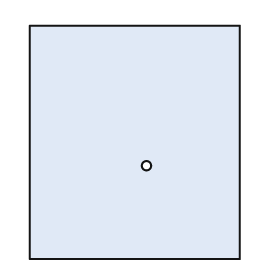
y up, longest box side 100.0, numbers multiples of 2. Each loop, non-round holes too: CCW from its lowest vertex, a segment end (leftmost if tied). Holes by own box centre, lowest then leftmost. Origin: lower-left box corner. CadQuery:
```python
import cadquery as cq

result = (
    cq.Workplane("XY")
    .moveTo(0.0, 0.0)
    .lineTo(90.0, 0.0)
    .lineTo(90.0, 100.0)
    .lineTo(0.0, 100.0)
    .close()
    .moveTo(50.0, 40.0)
    .circle(2.0)
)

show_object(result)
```